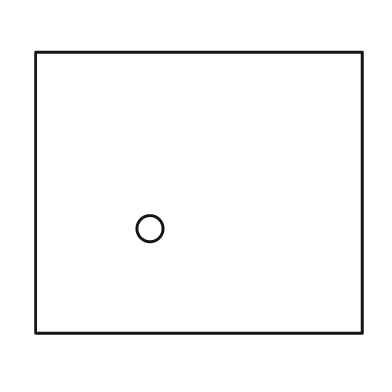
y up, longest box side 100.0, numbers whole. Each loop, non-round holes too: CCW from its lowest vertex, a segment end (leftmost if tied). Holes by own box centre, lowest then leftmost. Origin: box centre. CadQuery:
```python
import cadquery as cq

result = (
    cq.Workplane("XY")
    .moveTo(-50.0, -43.0)
    .lineTo(50.0, -43.0)
    .lineTo(50.0, 43.0)
    .lineTo(-50.0, 43.0)
    .close()
    .moveTo(-15.0, -11.0)
    .circle(4.0)
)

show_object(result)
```